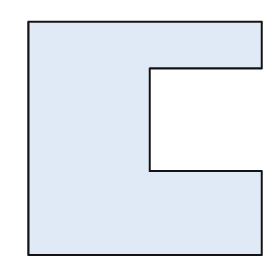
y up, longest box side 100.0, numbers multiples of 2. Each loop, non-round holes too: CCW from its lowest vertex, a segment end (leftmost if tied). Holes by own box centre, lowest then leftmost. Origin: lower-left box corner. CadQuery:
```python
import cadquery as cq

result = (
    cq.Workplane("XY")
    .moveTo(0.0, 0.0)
    .lineTo(100.0, 0.0)
    .lineTo(100.0, 36.0)
    .lineTo(52.0, 36.0)
    .lineTo(52.0, 80.0)
    .lineTo(100.0, 80.0)
    .lineTo(100.0, 100.0)
    .lineTo(0.0, 100.0)
    .close()
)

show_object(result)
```